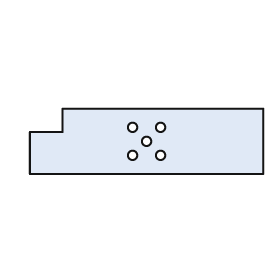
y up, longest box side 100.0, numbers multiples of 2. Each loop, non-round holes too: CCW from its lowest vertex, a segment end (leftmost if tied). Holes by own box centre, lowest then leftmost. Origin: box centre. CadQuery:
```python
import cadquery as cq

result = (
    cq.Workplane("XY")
    .moveTo(-50.0, -14.0)
    .lineTo(50.0, -14.0)
    .lineTo(50.0, 14.0)
    .lineTo(-36.0, 14.0)
    .lineTo(-36.0, 4.0)
    .lineTo(-50.0, 4.0)
    .close()
    .moveTo(-6.0, -6.0)
    .circle(2.0)
    .moveTo(6.0, -6.0)
    .circle(2.0)
    .moveTo(0.0, 0.0)
    .circle(2.0)
    .moveTo(-6.0, 6.0)
    .circle(2.0)
    .moveTo(6.0, 6.0)
    .circle(2.0)
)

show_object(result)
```